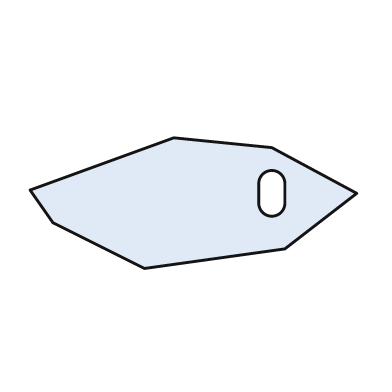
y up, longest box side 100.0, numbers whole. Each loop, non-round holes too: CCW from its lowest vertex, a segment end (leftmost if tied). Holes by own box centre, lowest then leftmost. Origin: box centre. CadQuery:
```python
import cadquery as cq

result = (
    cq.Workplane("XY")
    .moveTo(-15.0, -20.0)
    .lineTo(28.0, -14.0)
    .lineTo(50.0, 3.0)
    .lineTo(24.0, 17.0)
    .lineTo(-6.0, 20.0)
    .lineTo(-50.0, 4.0)
    .lineTo(-43.0, -6.0)
    .close()
    .moveTo(20.0, 0.0)
    .threePointArc((24.0, -4.0), (28.0, 0.0))
    .lineTo(28.0, 6.0)
    .threePointArc((24.0, 10.0), (20.0, 6.0))
    .close()
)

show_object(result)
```